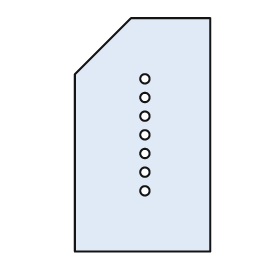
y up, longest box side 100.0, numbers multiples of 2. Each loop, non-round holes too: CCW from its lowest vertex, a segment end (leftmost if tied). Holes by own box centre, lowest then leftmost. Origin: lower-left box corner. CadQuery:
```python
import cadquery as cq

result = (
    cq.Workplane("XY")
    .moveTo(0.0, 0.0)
    .lineTo(58.0, 0.0)
    .lineTo(58.0, 100.0)
    .lineTo(24.0, 100.0)
    .lineTo(0.0, 76.0)
    .close()
    .moveTo(30.0, 26.0)
    .circle(2.0)
    .moveTo(30.0, 34.0)
    .circle(2.0)
    .moveTo(30.0, 42.0)
    .circle(2.0)
    .moveTo(30.0, 50.0)
    .circle(2.0)
    .moveTo(30.0, 58.0)
    .circle(2.0)
    .moveTo(30.0, 66.0)
    .circle(2.0)
    .moveTo(30.0, 74.0)
    .circle(2.0)
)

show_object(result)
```